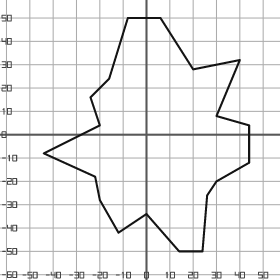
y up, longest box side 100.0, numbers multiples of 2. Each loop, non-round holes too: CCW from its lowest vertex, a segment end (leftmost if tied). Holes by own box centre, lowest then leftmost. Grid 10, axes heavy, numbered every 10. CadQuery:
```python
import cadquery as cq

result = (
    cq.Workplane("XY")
    .moveTo(14.0, -50.0)
    .lineTo(24.0, -50.0)
    .lineTo(26.0, -26.0)
    .lineTo(30.0, -20.0)
    .lineTo(44.0, -12.0)
    .lineTo(44.0, 4.0)
    .lineTo(30.0, 8.0)
    .lineTo(40.0, 32.0)
    .lineTo(20.0, 28.0)
    .lineTo(6.0, 50.0)
    .lineTo(-8.0, 50.0)
    .lineTo(-16.0, 24.0)
    .lineTo(-24.0, 16.0)
    .lineTo(-20.0, 4.0)
    .lineTo(-44.0, -8.0)
    .lineTo(-22.0, -18.0)
    .lineTo(-20.0, -28.0)
    .lineTo(-12.0, -42.0)
    .lineTo(0.0, -34.0)
    .close()
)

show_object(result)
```